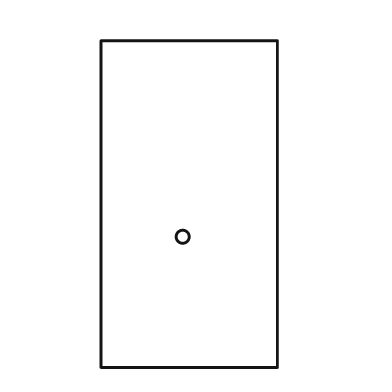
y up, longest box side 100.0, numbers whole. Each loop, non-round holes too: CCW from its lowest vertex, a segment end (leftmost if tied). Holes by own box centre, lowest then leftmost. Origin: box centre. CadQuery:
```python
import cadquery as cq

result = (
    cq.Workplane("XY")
    .moveTo(-27.0, -50.0)
    .lineTo(27.0, -50.0)
    .lineTo(27.0, 50.0)
    .lineTo(-27.0, 50.0)
    .close()
    .moveTo(-2.0, -10.0)
    .circle(2.0)
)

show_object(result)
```